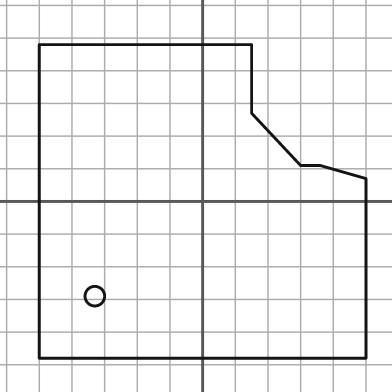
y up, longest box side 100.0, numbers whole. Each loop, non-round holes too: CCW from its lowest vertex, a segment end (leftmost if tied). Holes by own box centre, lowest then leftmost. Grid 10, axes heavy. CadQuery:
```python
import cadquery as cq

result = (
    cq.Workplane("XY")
    .moveTo(-50.0, -48.0)
    .lineTo(50.0, -48.0)
    .lineTo(50.0, 7.0)
    .lineTo(36.0, 11.0)
    .lineTo(30.0, 11.0)
    .lineTo(15.0, 27.0)
    .lineTo(15.0, 48.0)
    .lineTo(-50.0, 48.0)
    .close()
    .moveTo(-33.0, -29.0)
    .circle(3.0)
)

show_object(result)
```